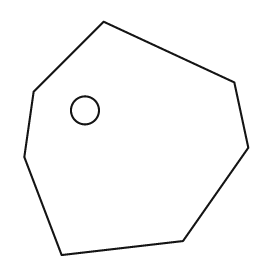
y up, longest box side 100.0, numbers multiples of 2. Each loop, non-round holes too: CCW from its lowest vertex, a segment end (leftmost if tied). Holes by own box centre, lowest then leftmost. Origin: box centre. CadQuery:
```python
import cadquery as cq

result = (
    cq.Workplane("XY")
    .moveTo(-32.0, -50.0)
    .lineTo(20.0, -44.0)
    .lineTo(48.0, -4.0)
    .lineTo(42.0, 24.0)
    .lineTo(-14.0, 50.0)
    .lineTo(-44.0, 20.0)
    .lineTo(-48.0, -8.0)
    .close()
    .moveTo(-22.0, 12.0)
    .circle(6.0)
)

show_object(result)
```